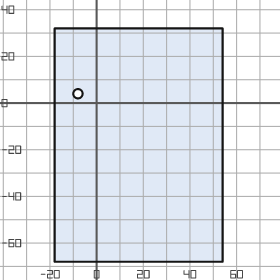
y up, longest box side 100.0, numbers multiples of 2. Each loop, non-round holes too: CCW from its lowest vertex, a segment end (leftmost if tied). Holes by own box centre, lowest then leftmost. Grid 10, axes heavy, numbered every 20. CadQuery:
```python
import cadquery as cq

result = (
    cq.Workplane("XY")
    .moveTo(-18.0, -68.0)
    .lineTo(54.0, -68.0)
    .lineTo(54.0, 32.0)
    .lineTo(-18.0, 32.0)
    .close()
    .moveTo(-8.0, 4.0)
    .circle(2.0)
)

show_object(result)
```